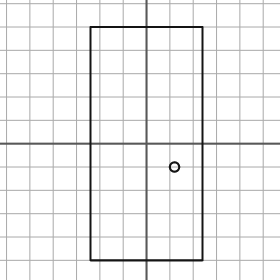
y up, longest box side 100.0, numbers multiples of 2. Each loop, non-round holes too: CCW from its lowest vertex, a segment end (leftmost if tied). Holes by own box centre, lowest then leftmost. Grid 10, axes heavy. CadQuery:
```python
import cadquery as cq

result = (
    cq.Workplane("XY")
    .moveTo(-24.0, -50.0)
    .lineTo(24.0, -50.0)
    .lineTo(24.0, 50.0)
    .lineTo(-24.0, 50.0)
    .close()
    .moveTo(12.0, -10.0)
    .circle(2.0)
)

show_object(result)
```